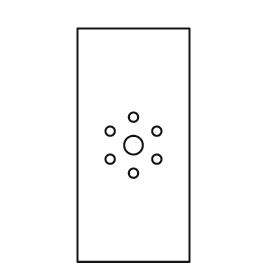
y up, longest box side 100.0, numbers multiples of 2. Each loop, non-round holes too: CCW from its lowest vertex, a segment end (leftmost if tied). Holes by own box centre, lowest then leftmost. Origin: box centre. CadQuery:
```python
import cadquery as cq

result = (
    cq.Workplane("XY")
    .moveTo(-24.0, -50.0)
    .lineTo(24.0, -50.0)
    .lineTo(24.0, 50.0)
    .lineTo(-24.0, 50.0)
    .close()
    .moveTo(0.0, -12.0)
    .circle(2.0)
    .moveTo(-10.0, -6.0)
    .circle(2.0)
    .moveTo(10.0, -6.0)
    .circle(2.0)
    .moveTo(0.0, 0.0)
    .circle(4.0)
    .moveTo(-10.0, 6.0)
    .circle(2.0)
    .moveTo(10.0, 6.0)
    .circle(2.0)
    .moveTo(0.0, 12.0)
    .circle(2.0)
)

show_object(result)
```